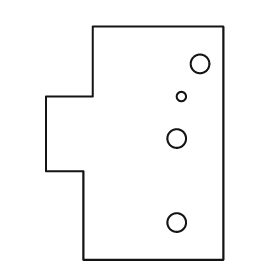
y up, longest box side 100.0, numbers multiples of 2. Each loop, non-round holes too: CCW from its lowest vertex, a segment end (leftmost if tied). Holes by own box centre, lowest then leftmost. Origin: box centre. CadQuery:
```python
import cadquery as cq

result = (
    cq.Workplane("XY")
    .moveTo(-22.0, -50.0)
    .lineTo(38.0, -50.0)
    .lineTo(38.0, 50.0)
    .lineTo(-18.0, 50.0)
    .lineTo(-18.0, 20.0)
    .lineTo(-38.0, 20.0)
    .lineTo(-38.0, -12.0)
    .lineTo(-22.0, -12.0)
    .close()
    .moveTo(18.0, -34.0)
    .circle(4.0)
    .moveTo(18.0, 2.0)
    .circle(4.0)
    .moveTo(20.0, 20.0)
    .circle(2.0)
    .moveTo(28.0, 34.0)
    .circle(4.0)
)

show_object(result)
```